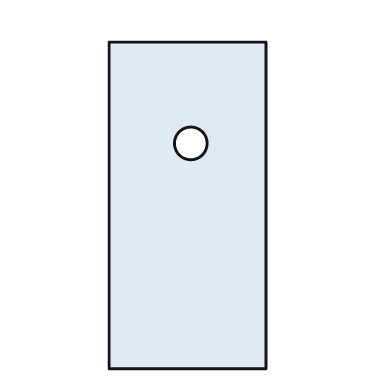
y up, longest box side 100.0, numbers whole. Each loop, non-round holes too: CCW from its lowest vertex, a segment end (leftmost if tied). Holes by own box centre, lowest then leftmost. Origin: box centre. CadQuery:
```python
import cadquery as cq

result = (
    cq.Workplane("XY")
    .moveTo(-24.0, -50.0)
    .lineTo(24.0, -50.0)
    .lineTo(24.0, 50.0)
    .lineTo(-24.0, 50.0)
    .close()
    .moveTo(1.0, 19.0)
    .circle(5.0)
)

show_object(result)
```